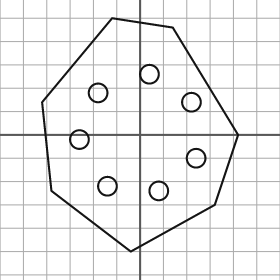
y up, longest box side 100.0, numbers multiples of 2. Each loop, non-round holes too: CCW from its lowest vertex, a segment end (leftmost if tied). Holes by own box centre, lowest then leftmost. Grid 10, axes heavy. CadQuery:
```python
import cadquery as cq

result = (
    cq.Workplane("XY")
    .moveTo(-4.0, -50.0)
    .lineTo(32.0, -30.0)
    .lineTo(42.0, 0.0)
    .lineTo(14.0, 46.0)
    .lineTo(-12.0, 50.0)
    .lineTo(-42.0, 14.0)
    .lineTo(-38.0, -24.0)
    .close()
    .moveTo(8.0, -24.0)
    .circle(4.0)
    .moveTo(-14.0, -22.0)
    .circle(4.0)
    .moveTo(24.0, -10.0)
    .circle(4.0)
    .moveTo(-26.0, -2.0)
    .circle(4.0)
    .moveTo(22.0, 14.0)
    .circle(4.0)
    .moveTo(-18.0, 18.0)
    .circle(4.0)
    .moveTo(4.0, 26.0)
    .circle(4.0)
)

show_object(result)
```